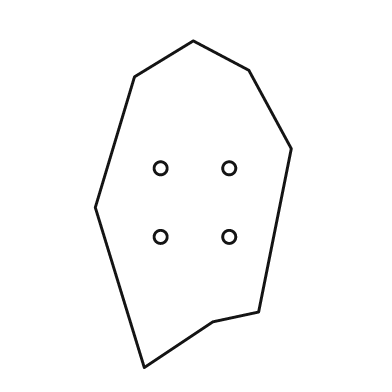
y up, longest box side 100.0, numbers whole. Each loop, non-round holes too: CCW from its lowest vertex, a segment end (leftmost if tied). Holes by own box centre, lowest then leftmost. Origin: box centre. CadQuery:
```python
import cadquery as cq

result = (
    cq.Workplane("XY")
    .moveTo(-15.0, -50.0)
    .lineTo(6.0, -36.0)
    .lineTo(20.0, -33.0)
    .lineTo(30.0, 17.0)
    .lineTo(17.0, 41.0)
    .lineTo(0.0, 50.0)
    .lineTo(-18.0, 39.0)
    .lineTo(-30.0, -1.0)
    .close()
    .moveTo(-10.0, -10.0)
    .circle(2.0)
    .moveTo(11.0, -10.0)
    .circle(2.0)
    .moveTo(-10.0, 11.0)
    .circle(2.0)
    .moveTo(11.0, 11.0)
    .circle(2.0)
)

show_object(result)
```